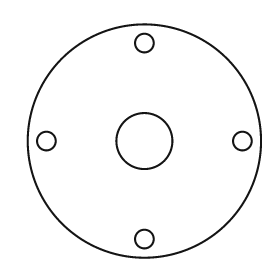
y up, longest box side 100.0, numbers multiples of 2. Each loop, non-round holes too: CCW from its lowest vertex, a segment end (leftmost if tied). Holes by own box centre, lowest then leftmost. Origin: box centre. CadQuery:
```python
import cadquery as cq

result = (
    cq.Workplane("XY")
    .moveTo(0.0, 0.0)
    .circle(50.0)
    .moveTo(0.0, -42.0)
    .circle(4.0)
    .moveTo(-42.0, 0.0)
    .circle(4.0)
    .moveTo(0.0, 0.0)
    .circle(12.0)
    .moveTo(42.0, 0.0)
    .circle(4.0)
    .moveTo(0.0, 42.0)
    .circle(4.0)
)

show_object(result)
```